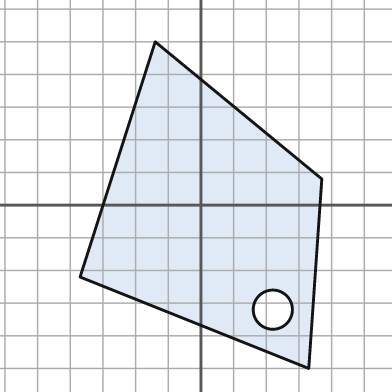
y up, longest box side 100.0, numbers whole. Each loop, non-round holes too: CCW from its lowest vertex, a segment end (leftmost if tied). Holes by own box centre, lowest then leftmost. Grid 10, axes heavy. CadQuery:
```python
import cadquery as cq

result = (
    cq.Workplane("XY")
    .moveTo(33.0, -50.0)
    .lineTo(37.0, 8.0)
    .lineTo(-14.0, 50.0)
    .lineTo(-37.0, -22.0)
    .close()
    .moveTo(22.0, -32.0)
    .circle(6.0)
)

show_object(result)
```